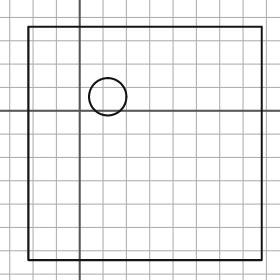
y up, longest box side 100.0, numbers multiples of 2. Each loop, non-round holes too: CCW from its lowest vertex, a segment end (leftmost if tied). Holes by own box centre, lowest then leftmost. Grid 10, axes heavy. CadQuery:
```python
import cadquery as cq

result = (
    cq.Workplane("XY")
    .moveTo(-22.0, -64.0)
    .lineTo(78.0, -64.0)
    .lineTo(78.0, 36.0)
    .lineTo(-22.0, 36.0)
    .close()
    .moveTo(12.0, 6.0)
    .circle(8.0)
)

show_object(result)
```